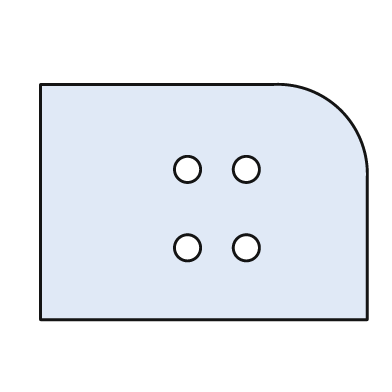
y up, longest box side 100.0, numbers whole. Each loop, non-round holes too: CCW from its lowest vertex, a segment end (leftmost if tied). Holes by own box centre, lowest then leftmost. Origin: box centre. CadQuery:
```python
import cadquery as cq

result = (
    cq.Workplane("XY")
    .moveTo(-50.0, -36.0)
    .lineTo(50.0, -36.0)
    .lineTo(50.0, 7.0)
    .threePointArc((42.0, 28.0), (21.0, 36.0))
    .lineTo(-50.0, 36.0)
    .close()
    .moveTo(-5.0, -14.0)
    .circle(4.0)
    .moveTo(13.0, -14.0)
    .circle(4.0)
    .moveTo(-5.0, 10.0)
    .circle(4.0)
    .moveTo(13.0, 10.0)
    .circle(4.0)
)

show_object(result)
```